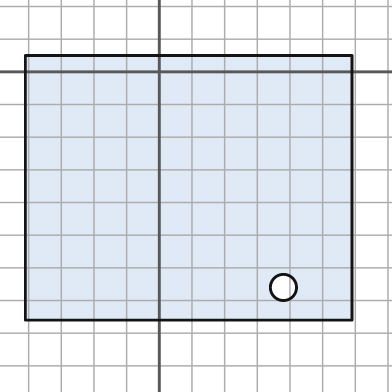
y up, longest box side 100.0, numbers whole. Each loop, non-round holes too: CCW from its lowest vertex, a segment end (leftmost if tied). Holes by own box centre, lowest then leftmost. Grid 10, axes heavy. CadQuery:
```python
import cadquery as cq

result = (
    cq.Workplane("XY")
    .moveTo(-41.0, -76.0)
    .lineTo(59.0, -76.0)
    .lineTo(59.0, 5.0)
    .lineTo(-41.0, 5.0)
    .close()
    .moveTo(38.0, -66.0)
    .circle(4.0)
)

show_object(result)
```